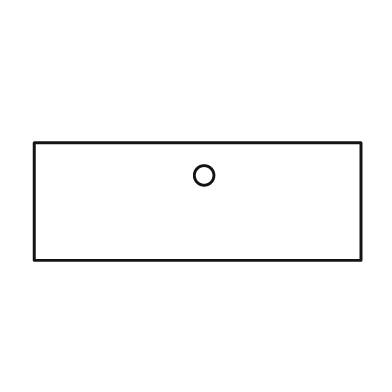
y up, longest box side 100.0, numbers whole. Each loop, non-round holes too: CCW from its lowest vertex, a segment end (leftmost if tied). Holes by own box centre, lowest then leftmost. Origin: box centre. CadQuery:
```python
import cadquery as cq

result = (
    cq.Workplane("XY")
    .moveTo(-50.0, -18.0)
    .lineTo(50.0, -18.0)
    .lineTo(50.0, 18.0)
    .lineTo(-50.0, 18.0)
    .close()
    .moveTo(2.0, 8.0)
    .circle(3.0)
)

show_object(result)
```